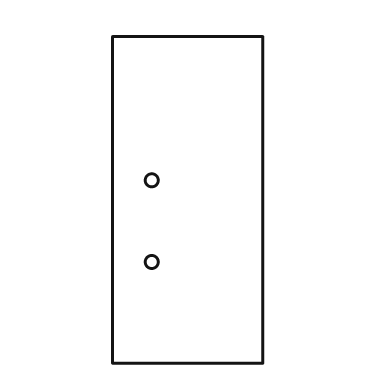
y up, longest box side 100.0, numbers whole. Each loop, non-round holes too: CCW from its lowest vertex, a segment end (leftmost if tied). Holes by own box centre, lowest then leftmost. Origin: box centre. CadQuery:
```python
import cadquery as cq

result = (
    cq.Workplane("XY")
    .moveTo(-23.0, -50.0)
    .lineTo(23.0, -50.0)
    .lineTo(23.0, 50.0)
    .lineTo(-23.0, 50.0)
    .close()
    .moveTo(-11.0, -19.0)
    .circle(2.0)
    .moveTo(-11.0, 6.0)
    .circle(2.0)
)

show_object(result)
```